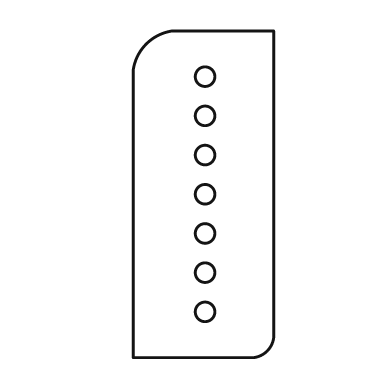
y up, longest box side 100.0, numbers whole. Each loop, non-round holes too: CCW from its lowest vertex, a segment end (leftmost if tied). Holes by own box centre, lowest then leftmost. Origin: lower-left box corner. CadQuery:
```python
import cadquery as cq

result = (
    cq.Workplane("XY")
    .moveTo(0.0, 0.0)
    .lineTo(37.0, 0.0)
    .threePointArc((41.0, 2.0), (43.0, 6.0))
    .lineTo(43.0, 100.0)
    .lineTo(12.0, 100.0)
    .threePointArc((4.0, 96.0), (0.0, 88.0))
    .close()
    .moveTo(22.0, 14.0)
    .circle(3.0)
    .moveTo(22.0, 26.0)
    .circle(3.0)
    .moveTo(22.0, 38.0)
    .circle(3.0)
    .moveTo(22.0, 50.0)
    .circle(3.0)
    .moveTo(22.0, 62.0)
    .circle(3.0)
    .moveTo(22.0, 74.0)
    .circle(3.0)
    .moveTo(22.0, 86.0)
    .circle(3.0)
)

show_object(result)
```